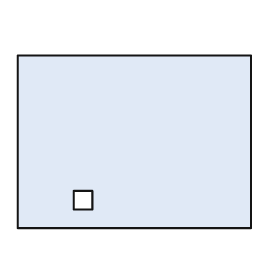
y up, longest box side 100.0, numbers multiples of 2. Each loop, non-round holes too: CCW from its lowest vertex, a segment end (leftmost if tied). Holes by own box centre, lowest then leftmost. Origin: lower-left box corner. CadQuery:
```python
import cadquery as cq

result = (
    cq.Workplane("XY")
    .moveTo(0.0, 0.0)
    .lineTo(100.0, 0.0)
    .lineTo(100.0, 74.0)
    .lineTo(0.0, 74.0)
    .close()
    .moveTo(24.0, 8.0)
    .lineTo(32.0, 8.0)
    .lineTo(32.0, 16.0)
    .lineTo(24.0, 16.0)
    .close()
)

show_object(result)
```